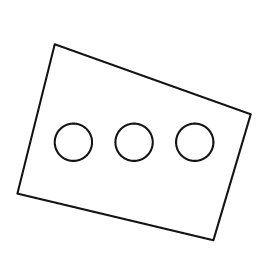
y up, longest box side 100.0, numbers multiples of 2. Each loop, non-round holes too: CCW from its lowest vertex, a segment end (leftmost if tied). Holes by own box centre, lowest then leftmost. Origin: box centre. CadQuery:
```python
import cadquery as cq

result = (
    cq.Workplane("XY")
    .moveTo(34.0, -42.0)
    .lineTo(50.0, 12.0)
    .lineTo(-34.0, 42.0)
    .lineTo(-50.0, -22.0)
    .close()
    .moveTo(-26.0, 0.0)
    .circle(8.0)
    .moveTo(0.0, 0.0)
    .circle(8.0)
    .moveTo(26.0, 0.0)
    .circle(8.0)
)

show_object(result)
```